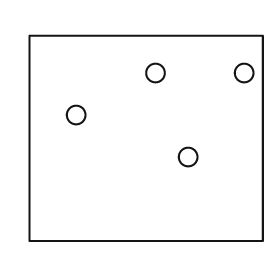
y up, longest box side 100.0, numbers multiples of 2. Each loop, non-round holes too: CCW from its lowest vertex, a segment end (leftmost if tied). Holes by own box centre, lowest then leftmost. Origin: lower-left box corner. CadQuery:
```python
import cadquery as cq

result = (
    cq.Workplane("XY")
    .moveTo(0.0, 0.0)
    .lineTo(100.0, 0.0)
    .lineTo(100.0, 88.0)
    .lineTo(0.0, 88.0)
    .close()
    .moveTo(68.0, 36.0)
    .circle(4.0)
    .moveTo(20.0, 54.0)
    .circle(4.0)
    .moveTo(54.0, 72.0)
    .circle(4.0)
    .moveTo(92.0, 72.0)
    .circle(4.0)
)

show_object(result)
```